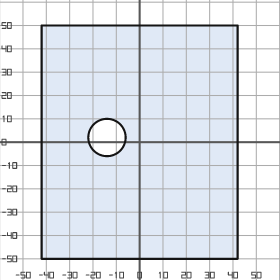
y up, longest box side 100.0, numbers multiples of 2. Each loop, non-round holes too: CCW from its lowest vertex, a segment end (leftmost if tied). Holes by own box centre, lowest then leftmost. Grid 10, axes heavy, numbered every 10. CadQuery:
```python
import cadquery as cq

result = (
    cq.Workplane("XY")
    .moveTo(-42.0, -50.0)
    .lineTo(42.0, -50.0)
    .lineTo(42.0, 50.0)
    .lineTo(-42.0, 50.0)
    .close()
    .moveTo(-14.0, 2.0)
    .circle(8.0)
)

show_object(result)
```